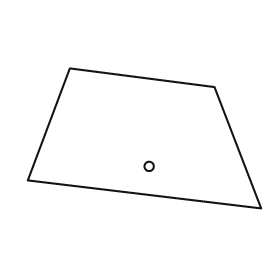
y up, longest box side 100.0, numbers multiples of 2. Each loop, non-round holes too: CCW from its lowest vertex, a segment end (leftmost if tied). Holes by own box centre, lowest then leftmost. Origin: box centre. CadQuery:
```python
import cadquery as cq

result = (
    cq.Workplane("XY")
    .moveTo(50.0, -30.0)
    .lineTo(30.0, 22.0)
    .lineTo(-32.0, 30.0)
    .lineTo(-50.0, -18.0)
    .close()
    .moveTo(2.0, -12.0)
    .circle(2.0)
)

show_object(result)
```